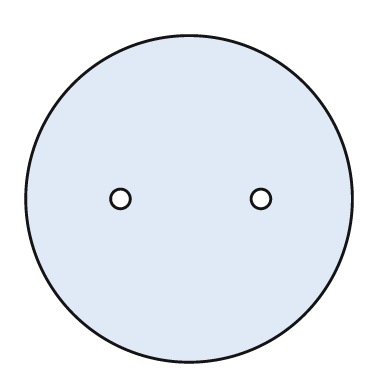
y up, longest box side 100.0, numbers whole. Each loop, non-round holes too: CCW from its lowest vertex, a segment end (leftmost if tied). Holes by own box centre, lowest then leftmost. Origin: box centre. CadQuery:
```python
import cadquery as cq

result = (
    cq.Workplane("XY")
    .moveTo(0.0, 0.0)
    .circle(50.0)
    .moveTo(-21.0, 0.0)
    .circle(3.0)
    .moveTo(22.0, 0.0)
    .circle(3.0)
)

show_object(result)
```